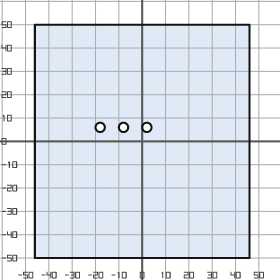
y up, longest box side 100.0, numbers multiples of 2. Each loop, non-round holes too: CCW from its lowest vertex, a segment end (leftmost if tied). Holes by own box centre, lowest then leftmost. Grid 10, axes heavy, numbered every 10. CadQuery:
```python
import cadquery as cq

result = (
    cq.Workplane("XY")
    .moveTo(-46.0, -50.0)
    .lineTo(46.0, -50.0)
    .lineTo(46.0, 50.0)
    .lineTo(-46.0, 50.0)
    .close()
    .moveTo(-18.0, 6.0)
    .circle(2.0)
    .moveTo(-8.0, 6.0)
    .circle(2.0)
    .moveTo(2.0, 6.0)
    .circle(2.0)
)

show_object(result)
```